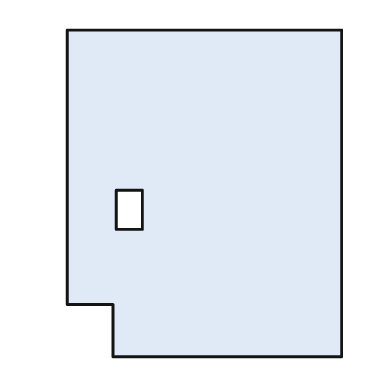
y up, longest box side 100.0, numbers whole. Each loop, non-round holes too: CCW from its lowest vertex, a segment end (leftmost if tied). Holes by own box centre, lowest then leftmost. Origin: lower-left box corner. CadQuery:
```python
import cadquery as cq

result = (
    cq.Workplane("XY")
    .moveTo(14.0, 0.0)
    .lineTo(84.0, 0.0)
    .lineTo(84.0, 100.0)
    .lineTo(0.0, 100.0)
    .lineTo(0.0, 16.0)
    .lineTo(14.0, 16.0)
    .close()
    .moveTo(15.0, 39.0)
    .lineTo(23.0, 39.0)
    .lineTo(23.0, 51.0)
    .lineTo(15.0, 51.0)
    .close()
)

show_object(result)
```